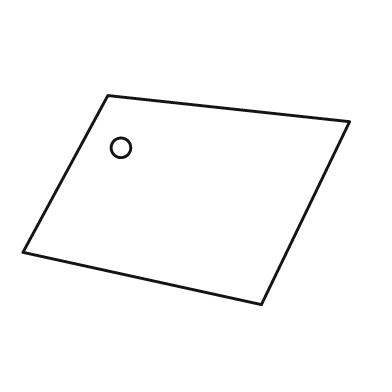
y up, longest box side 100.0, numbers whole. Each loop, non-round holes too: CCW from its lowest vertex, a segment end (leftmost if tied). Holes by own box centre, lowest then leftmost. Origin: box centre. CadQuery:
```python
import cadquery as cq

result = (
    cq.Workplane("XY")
    .moveTo(23.0, -32.0)
    .lineTo(50.0, 24.0)
    .lineTo(-24.0, 32.0)
    .lineTo(-50.0, -16.0)
    .close()
    .moveTo(-20.0, 16.0)
    .circle(3.0)
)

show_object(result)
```